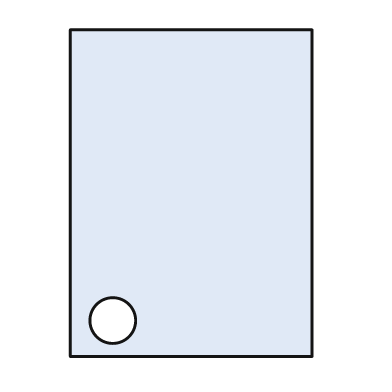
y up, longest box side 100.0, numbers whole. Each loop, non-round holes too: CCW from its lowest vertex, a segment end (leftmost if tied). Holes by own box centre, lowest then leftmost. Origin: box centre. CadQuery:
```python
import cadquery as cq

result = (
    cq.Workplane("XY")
    .moveTo(-37.0, -50.0)
    .lineTo(37.0, -50.0)
    .lineTo(37.0, 50.0)
    .lineTo(-37.0, 50.0)
    .close()
    .moveTo(-24.0, -39.0)
    .circle(7.0)
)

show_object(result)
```